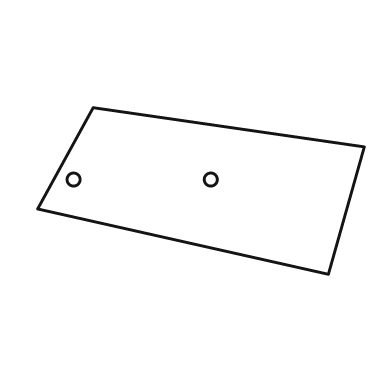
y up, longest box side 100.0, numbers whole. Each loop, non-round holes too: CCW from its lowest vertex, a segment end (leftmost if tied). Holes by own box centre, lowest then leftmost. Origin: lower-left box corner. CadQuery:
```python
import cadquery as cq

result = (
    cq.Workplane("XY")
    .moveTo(89.0, 0.0)
    .lineTo(100.0, 39.0)
    .lineTo(17.0, 51.0)
    .lineTo(0.0, 20.0)
    .close()
    .moveTo(11.0, 29.0)
    .circle(2.0)
    .moveTo(53.0, 29.0)
    .circle(2.0)
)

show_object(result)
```